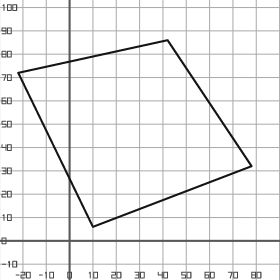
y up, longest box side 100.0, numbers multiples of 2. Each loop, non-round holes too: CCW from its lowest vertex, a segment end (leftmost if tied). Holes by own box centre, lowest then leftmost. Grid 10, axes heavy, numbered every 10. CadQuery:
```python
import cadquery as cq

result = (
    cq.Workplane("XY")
    .moveTo(10.0, 6.0)
    .lineTo(78.0, 32.0)
    .lineTo(42.0, 86.0)
    .lineTo(-22.0, 72.0)
    .close()
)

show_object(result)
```